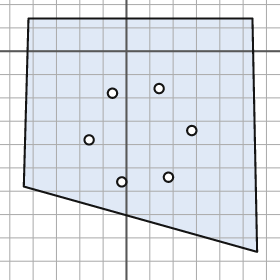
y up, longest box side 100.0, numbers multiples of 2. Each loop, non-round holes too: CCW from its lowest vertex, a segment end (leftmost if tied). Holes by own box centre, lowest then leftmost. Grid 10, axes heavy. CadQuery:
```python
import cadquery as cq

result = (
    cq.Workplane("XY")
    .moveTo(56.0, -86.0)
    .lineTo(54.0, 14.0)
    .lineTo(-42.0, 14.0)
    .lineTo(-44.0, -58.0)
    .close()
    .moveTo(-2.0, -56.0)
    .circle(2.0)
    .moveTo(18.0, -54.0)
    .circle(2.0)
    .moveTo(-16.0, -38.0)
    .circle(2.0)
    .moveTo(28.0, -34.0)
    .circle(2.0)
    .moveTo(-6.0, -18.0)
    .circle(2.0)
    .moveTo(14.0, -16.0)
    .circle(2.0)
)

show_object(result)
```